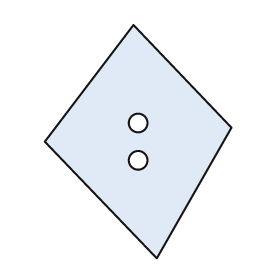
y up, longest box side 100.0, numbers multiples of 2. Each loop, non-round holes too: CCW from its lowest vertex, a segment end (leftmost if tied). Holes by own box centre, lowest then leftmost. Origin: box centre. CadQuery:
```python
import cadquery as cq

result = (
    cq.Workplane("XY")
    .moveTo(8.0, -50.0)
    .lineTo(40.0, 6.0)
    .lineTo(-2.0, 50.0)
    .lineTo(-40.0, 0.0)
    .close()
    .moveTo(0.0, -8.0)
    .circle(4.0)
    .moveTo(0.0, 8.0)
    .circle(4.0)
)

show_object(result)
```